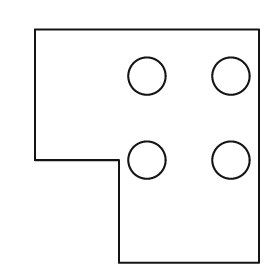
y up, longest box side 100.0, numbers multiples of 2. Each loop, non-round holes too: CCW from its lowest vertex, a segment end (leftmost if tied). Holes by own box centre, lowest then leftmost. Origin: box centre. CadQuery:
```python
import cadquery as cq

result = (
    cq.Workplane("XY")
    .moveTo(-12.0, -50.0)
    .lineTo(48.0, -50.0)
    .lineTo(48.0, 50.0)
    .lineTo(-48.0, 50.0)
    .lineTo(-48.0, -6.0)
    .lineTo(-12.0, -6.0)
    .close()
    .moveTo(0.0, -6.0)
    .circle(8.0)
    .moveTo(36.0, -6.0)
    .circle(8.0)
    .moveTo(0.0, 30.0)
    .circle(8.0)
    .moveTo(36.0, 30.0)
    .circle(8.0)
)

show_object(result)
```